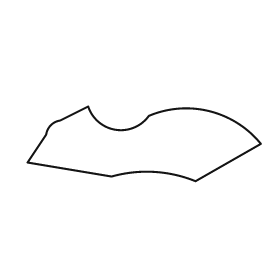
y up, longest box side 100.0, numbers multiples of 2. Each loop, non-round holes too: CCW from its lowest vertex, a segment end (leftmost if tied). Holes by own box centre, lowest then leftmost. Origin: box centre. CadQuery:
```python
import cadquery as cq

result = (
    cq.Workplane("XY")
    .moveTo(22.0, -16.0)
    .lineTo(50.0, 0.0)
    .threePointArc((28.0, 14.0), (2.0, 12.0))
    .threePointArc((-12.0, 6.0), (-24.0, 16.0))
    .lineTo(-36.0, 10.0)
    .threePointArc((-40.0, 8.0), (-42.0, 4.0))
    .lineTo(-50.0, -8.0)
    .lineTo(-14.0, -14.0)
    .threePointArc((4.0, -12.0), (22.0, -16.0))
    .close()
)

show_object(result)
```